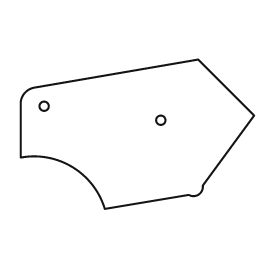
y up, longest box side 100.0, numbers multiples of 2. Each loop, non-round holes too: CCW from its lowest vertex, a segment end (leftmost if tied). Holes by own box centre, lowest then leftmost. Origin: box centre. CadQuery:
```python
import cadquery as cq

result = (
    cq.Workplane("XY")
    .moveTo(-14.0, -32.0)
    .lineTo(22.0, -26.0)
    .threePointArc((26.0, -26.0), (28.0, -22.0))
    .lineTo(50.0, 8.0)
    .lineTo(26.0, 32.0)
    .lineTo(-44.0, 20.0)
    .threePointArc((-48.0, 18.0), (-50.0, 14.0))
    .lineTo(-50.0, -10.0)
    .threePointArc((-28.0, -14.0), (-14.0, -32.0))
    .close()
    .moveTo(10.0, 6.0)
    .circle(2.0)
    .moveTo(-40.0, 12.0)
    .circle(2.0)
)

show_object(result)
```